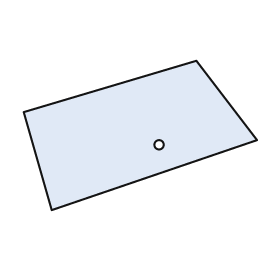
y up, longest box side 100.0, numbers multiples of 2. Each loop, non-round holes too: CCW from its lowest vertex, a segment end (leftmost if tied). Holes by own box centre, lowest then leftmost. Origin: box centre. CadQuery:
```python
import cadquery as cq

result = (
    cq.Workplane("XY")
    .moveTo(-38.0, -32.0)
    .lineTo(50.0, -2.0)
    .lineTo(24.0, 32.0)
    .lineTo(-50.0, 10.0)
    .close()
    .moveTo(8.0, -4.0)
    .circle(2.0)
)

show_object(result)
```